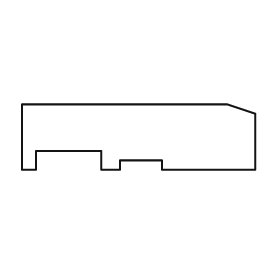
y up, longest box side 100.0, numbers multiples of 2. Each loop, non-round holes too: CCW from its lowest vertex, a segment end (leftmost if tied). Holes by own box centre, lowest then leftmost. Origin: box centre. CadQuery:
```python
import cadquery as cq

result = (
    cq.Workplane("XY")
    .moveTo(-50.0, -14.0)
    .lineTo(-44.0, -14.0)
    .lineTo(-44.0, -6.0)
    .lineTo(-16.0, -6.0)
    .lineTo(-16.0, -14.0)
    .lineTo(-8.0, -14.0)
    .lineTo(-8.0, -10.0)
    .lineTo(10.0, -10.0)
    .lineTo(10.0, -14.0)
    .lineTo(50.0, -14.0)
    .lineTo(50.0, 10.0)
    .lineTo(38.0, 14.0)
    .lineTo(-50.0, 14.0)
    .close()
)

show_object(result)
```